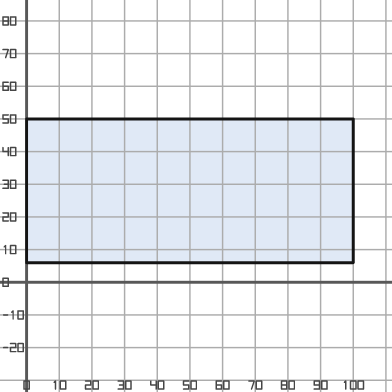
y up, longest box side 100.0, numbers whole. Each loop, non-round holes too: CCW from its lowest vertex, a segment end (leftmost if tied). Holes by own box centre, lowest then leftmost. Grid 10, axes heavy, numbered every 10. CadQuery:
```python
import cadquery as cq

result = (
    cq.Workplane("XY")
    .moveTo(0.0, 6.0)
    .lineTo(100.0, 6.0)
    .lineTo(100.0, 50.0)
    .lineTo(0.0, 50.0)
    .close()
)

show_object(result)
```